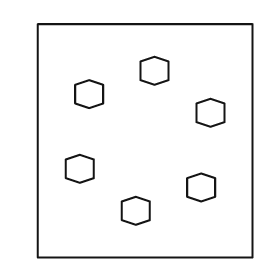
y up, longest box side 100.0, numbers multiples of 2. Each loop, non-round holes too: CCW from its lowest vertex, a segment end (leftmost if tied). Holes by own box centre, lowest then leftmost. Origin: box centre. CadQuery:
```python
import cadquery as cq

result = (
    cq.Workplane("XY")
    .moveTo(-46.0, -50.0)
    .lineTo(46.0, -50.0)
    .lineTo(46.0, 50.0)
    .lineTo(-46.0, 50.0)
    .close()
    .moveTo(-4.0, -36.0)
    .lineTo(2.0, -34.0)
    .lineTo(2.0, -26.0)
    .lineTo(-4.0, -24.0)
    .lineTo(-10.0, -26.0)
    .lineTo(-10.0, -34.0)
    .close()
    .moveTo(24.0, -26.0)
    .lineTo(30.0, -24.0)
    .lineTo(30.0, -16.0)
    .lineTo(24.0, -14.0)
    .lineTo(18.0, -16.0)
    .lineTo(18.0, -24.0)
    .close()
    .moveTo(-28.0, -18.0)
    .lineTo(-22.0, -16.0)
    .lineTo(-22.0, -8.0)
    .lineTo(-28.0, -6.0)
    .lineTo(-34.0, -8.0)
    .lineTo(-34.0, -16.0)
    .close()
    .moveTo(28.0, 6.0)
    .lineTo(34.0, 8.0)
    .lineTo(34.0, 16.0)
    .lineTo(28.0, 18.0)
    .lineTo(22.0, 16.0)
    .lineTo(22.0, 8.0)
    .close()
    .moveTo(-24.0, 14.0)
    .lineTo(-18.0, 16.0)
    .lineTo(-18.0, 24.0)
    .lineTo(-24.0, 26.0)
    .lineTo(-30.0, 24.0)
    .lineTo(-30.0, 16.0)
    .close()
    .moveTo(4.0, 24.0)
    .lineTo(10.0, 26.0)
    .lineTo(10.0, 34.0)
    .lineTo(4.0, 36.0)
    .lineTo(-2.0, 34.0)
    .lineTo(-2.0, 26.0)
    .close()
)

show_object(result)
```